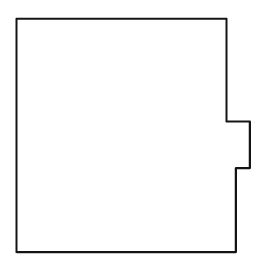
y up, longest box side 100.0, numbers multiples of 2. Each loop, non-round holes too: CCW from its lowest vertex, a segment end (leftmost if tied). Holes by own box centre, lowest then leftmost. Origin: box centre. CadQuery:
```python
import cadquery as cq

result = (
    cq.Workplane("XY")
    .moveTo(-50.0, -50.0)
    .lineTo(44.0, -50.0)
    .lineTo(44.0, -14.0)
    .lineTo(50.0, -14.0)
    .lineTo(50.0, 6.0)
    .lineTo(40.0, 6.0)
    .lineTo(40.0, 50.0)
    .lineTo(-50.0, 50.0)
    .close()
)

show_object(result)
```